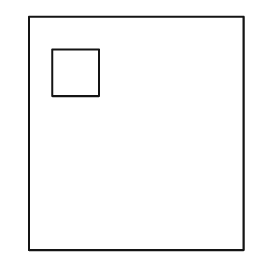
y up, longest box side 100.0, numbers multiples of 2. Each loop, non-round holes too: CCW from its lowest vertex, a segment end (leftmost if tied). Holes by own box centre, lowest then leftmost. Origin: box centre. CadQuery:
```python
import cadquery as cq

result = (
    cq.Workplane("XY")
    .moveTo(-46.0, -50.0)
    .lineTo(46.0, -50.0)
    .lineTo(46.0, 50.0)
    .lineTo(-46.0, 50.0)
    .close()
    .moveTo(-36.0, 16.0)
    .lineTo(-16.0, 16.0)
    .lineTo(-16.0, 36.0)
    .lineTo(-36.0, 36.0)
    .close()
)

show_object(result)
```